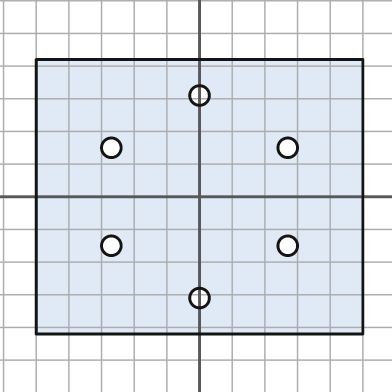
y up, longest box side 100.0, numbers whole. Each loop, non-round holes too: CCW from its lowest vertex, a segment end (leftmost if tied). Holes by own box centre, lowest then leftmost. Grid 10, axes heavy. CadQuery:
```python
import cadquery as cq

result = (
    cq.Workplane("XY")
    .moveTo(-50.0, -42.0)
    .lineTo(50.0, -42.0)
    .lineTo(50.0, 42.0)
    .lineTo(-50.0, 42.0)
    .close()
    .moveTo(0.0, -31.0)
    .circle(3.0)
    .moveTo(-27.0, -15.0)
    .circle(3.0)
    .moveTo(27.0, -15.0)
    .circle(3.0)
    .moveTo(-27.0, 15.0)
    .circle(3.0)
    .moveTo(27.0, 15.0)
    .circle(3.0)
    .moveTo(0.0, 31.0)
    .circle(3.0)
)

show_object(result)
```